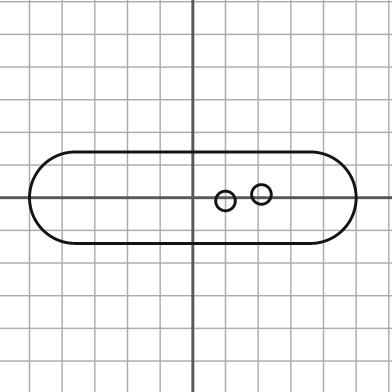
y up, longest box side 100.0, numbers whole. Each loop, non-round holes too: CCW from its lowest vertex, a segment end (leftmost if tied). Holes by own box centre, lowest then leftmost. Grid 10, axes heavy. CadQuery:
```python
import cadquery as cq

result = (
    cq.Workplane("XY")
    .moveTo(-36.0, -14.0)
    .lineTo(36.0, -14.0)
    .threePointArc((50.0, 0.0), (36.0, 14.0))
    .lineTo(-36.0, 14.0)
    .threePointArc((-50.0, 0.0), (-36.0, -14.0))
    .close()
    .moveTo(10.0, -1.0)
    .circle(3.0)
    .moveTo(21.0, 1.0)
    .circle(3.0)
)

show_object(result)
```